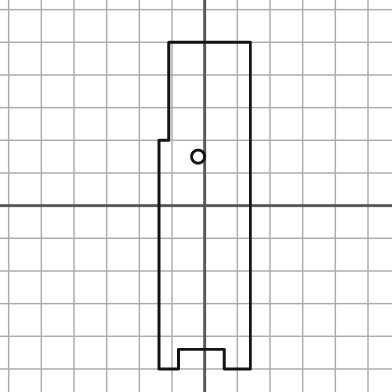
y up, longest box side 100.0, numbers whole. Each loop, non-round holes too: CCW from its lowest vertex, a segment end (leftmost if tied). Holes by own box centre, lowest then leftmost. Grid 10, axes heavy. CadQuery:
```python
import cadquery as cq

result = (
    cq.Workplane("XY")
    .moveTo(-14.0, -50.0)
    .lineTo(-8.0, -50.0)
    .lineTo(-8.0, -44.0)
    .lineTo(6.0, -44.0)
    .lineTo(6.0, -50.0)
    .lineTo(14.0, -50.0)
    .lineTo(14.0, 50.0)
    .lineTo(-11.0, 50.0)
    .lineTo(-11.0, 20.0)
    .lineTo(-14.0, 20.0)
    .close()
    .moveTo(-2.0, 15.0)
    .circle(2.0)
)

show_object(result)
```